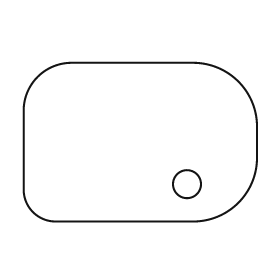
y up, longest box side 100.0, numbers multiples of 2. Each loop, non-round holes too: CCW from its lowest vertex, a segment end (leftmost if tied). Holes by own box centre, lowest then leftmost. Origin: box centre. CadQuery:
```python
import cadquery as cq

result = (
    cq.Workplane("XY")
    .moveTo(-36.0, -34.0)
    .lineTo(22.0, -34.0)
    .threePointArc((42.0, -26.0), (50.0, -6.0))
    .lineTo(50.0, 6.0)
    .threePointArc((42.0, 26.0), (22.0, 34.0))
    .lineTo(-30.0, 34.0)
    .threePointArc((-44.0, 28.0), (-50.0, 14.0))
    .lineTo(-50.0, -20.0)
    .threePointArc((-46.0, -30.0), (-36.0, -34.0))
    .close()
    .moveTo(20.0, -18.0)
    .circle(6.0)
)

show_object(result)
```